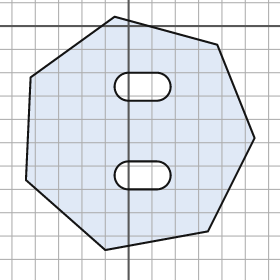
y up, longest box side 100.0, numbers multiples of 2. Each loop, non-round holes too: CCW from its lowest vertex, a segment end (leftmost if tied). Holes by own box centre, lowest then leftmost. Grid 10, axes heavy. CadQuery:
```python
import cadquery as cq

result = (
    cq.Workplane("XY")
    .moveTo(-10.0, -96.0)
    .lineTo(34.0, -88.0)
    .lineTo(54.0, -48.0)
    .lineTo(38.0, -8.0)
    .lineTo(-6.0, 4.0)
    .lineTo(-42.0, -22.0)
    .lineTo(-44.0, -66.0)
    .close()
    .moveTo(0.0, -70.0)
    .lineTo(12.0, -70.0)
    .threePointArc((18.0, -64.0), (12.0, -58.0))
    .lineTo(0.0, -58.0)
    .threePointArc((-6.0, -64.0), (0.0, -70.0))
    .close()
    .moveTo(0.0, -32.0)
    .lineTo(12.0, -32.0)
    .threePointArc((18.0, -26.0), (12.0, -20.0))
    .lineTo(0.0, -20.0)
    .threePointArc((-6.0, -26.0), (0.0, -32.0))
    .close()
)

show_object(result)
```